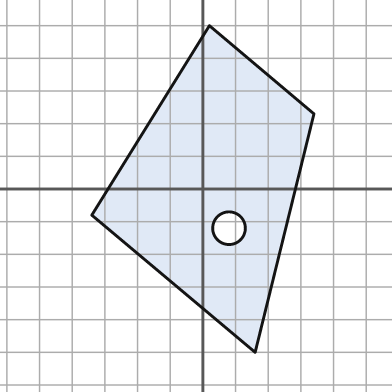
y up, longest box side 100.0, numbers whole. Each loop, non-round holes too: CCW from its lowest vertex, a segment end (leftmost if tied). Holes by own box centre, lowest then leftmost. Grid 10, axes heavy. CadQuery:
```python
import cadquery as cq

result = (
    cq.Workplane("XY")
    .moveTo(16.0, -50.0)
    .lineTo(34.0, 23.0)
    .lineTo(2.0, 50.0)
    .lineTo(-34.0, -8.0)
    .close()
    .moveTo(8.0, -12.0)
    .circle(5.0)
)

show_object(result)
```